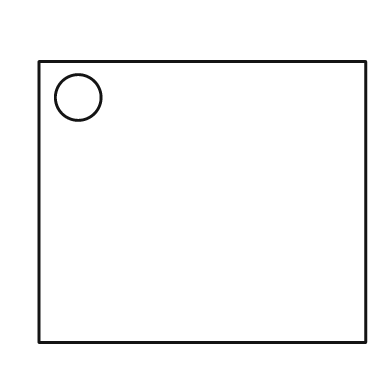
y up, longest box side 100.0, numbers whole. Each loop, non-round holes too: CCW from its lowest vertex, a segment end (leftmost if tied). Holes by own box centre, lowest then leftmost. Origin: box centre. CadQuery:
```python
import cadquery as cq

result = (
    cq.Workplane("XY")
    .moveTo(-50.0, -43.0)
    .lineTo(50.0, -43.0)
    .lineTo(50.0, 43.0)
    .lineTo(-50.0, 43.0)
    .close()
    .moveTo(-38.0, 32.0)
    .circle(7.0)
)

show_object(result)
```